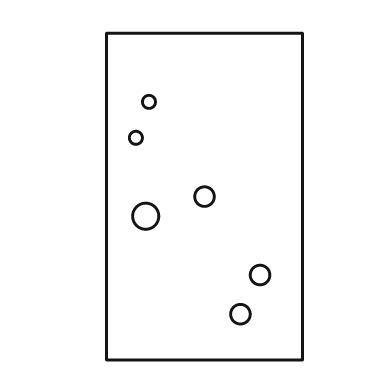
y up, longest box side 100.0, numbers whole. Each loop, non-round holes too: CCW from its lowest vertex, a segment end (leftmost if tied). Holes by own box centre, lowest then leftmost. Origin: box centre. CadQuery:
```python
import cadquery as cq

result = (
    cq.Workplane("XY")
    .moveTo(-30.0, -50.0)
    .lineTo(30.0, -50.0)
    .lineTo(30.0, 50.0)
    .lineTo(-30.0, 50.0)
    .close()
    .moveTo(11.0, -36.0)
    .circle(3.0)
    .moveTo(17.0, -24.0)
    .circle(3.0)
    .moveTo(-18.0, -6.0)
    .circle(4.0)
    .moveTo(0.0, 0.0)
    .circle(3.0)
    .moveTo(-21.0, 18.0)
    .circle(2.0)
    .moveTo(-17.0, 29.0)
    .circle(2.0)
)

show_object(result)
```